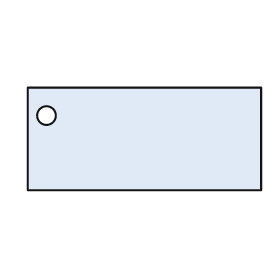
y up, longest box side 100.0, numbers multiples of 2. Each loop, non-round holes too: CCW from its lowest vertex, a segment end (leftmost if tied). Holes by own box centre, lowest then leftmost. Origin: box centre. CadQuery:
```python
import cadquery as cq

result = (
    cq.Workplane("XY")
    .moveTo(-50.0, -22.0)
    .lineTo(50.0, -22.0)
    .lineTo(50.0, 22.0)
    .lineTo(-50.0, 22.0)
    .close()
    .moveTo(-42.0, 10.0)
    .circle(4.0)
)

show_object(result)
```